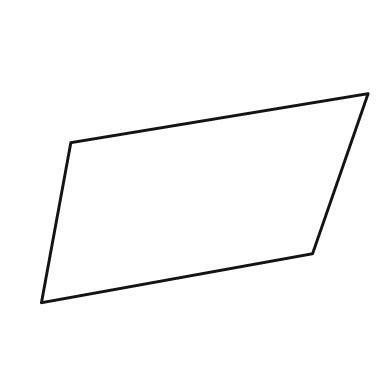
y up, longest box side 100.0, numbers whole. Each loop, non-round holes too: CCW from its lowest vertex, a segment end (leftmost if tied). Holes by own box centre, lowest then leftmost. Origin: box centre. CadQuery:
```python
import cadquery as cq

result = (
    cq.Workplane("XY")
    .moveTo(-50.0, -32.0)
    .lineTo(33.0, -17.0)
    .lineTo(50.0, 32.0)
    .lineTo(-41.0, 17.0)
    .close()
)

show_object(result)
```